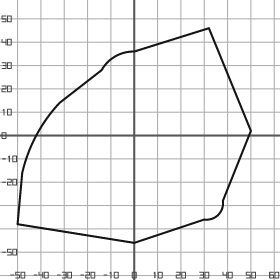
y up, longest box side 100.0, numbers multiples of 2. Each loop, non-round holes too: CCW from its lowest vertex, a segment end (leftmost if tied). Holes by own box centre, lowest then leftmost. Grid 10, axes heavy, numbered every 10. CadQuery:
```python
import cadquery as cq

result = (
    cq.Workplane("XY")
    .moveTo(0.0, -46.0)
    .lineTo(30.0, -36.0)
    .threePointArc((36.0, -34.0), (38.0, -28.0))
    .lineTo(50.0, 2.0)
    .lineTo(32.0, 46.0)
    .lineTo(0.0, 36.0)
    .threePointArc((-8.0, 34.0), (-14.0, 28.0))
    .lineTo(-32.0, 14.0)
    .threePointArc((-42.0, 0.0), (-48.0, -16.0))
    .lineTo(-50.0, -38.0)
    .close()
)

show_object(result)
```